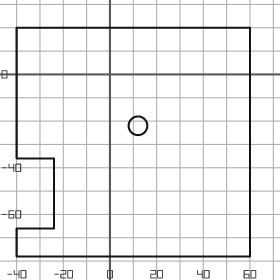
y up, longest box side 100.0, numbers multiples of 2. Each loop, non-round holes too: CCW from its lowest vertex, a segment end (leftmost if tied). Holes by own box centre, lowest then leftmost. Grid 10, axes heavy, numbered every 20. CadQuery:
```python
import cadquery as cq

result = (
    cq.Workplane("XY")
    .moveTo(-40.0, -78.0)
    .lineTo(60.0, -78.0)
    .lineTo(60.0, 20.0)
    .lineTo(-40.0, 20.0)
    .lineTo(-40.0, -36.0)
    .lineTo(-24.0, -36.0)
    .lineTo(-24.0, -66.0)
    .lineTo(-40.0, -66.0)
    .close()
    .moveTo(12.0, -22.0)
    .circle(4.0)
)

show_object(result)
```